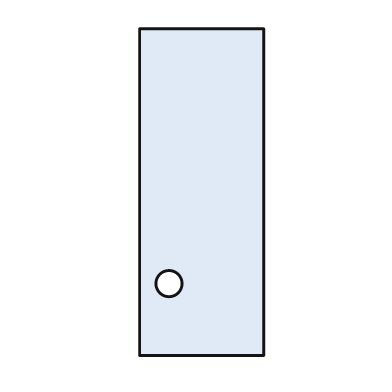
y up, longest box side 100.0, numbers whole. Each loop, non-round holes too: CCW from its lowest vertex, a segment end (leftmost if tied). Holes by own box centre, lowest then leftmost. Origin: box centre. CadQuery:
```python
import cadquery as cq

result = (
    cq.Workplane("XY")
    .moveTo(-19.0, -50.0)
    .lineTo(19.0, -50.0)
    .lineTo(19.0, 50.0)
    .lineTo(-19.0, 50.0)
    .close()
    .moveTo(-10.0, -28.0)
    .circle(4.0)
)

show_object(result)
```